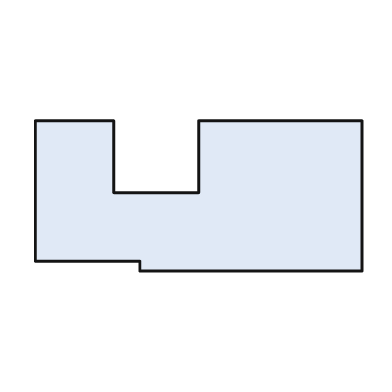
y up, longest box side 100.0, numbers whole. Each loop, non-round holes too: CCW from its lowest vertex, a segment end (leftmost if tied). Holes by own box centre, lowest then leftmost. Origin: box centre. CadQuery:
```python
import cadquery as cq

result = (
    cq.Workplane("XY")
    .moveTo(-18.0, -23.0)
    .lineTo(50.0, -23.0)
    .lineTo(50.0, 23.0)
    .lineTo(0.0, 23.0)
    .lineTo(0.0, 1.0)
    .lineTo(-26.0, 1.0)
    .lineTo(-26.0, 23.0)
    .lineTo(-50.0, 23.0)
    .lineTo(-50.0, -20.0)
    .lineTo(-18.0, -20.0)
    .close()
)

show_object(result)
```